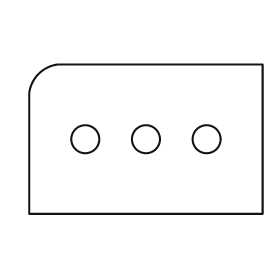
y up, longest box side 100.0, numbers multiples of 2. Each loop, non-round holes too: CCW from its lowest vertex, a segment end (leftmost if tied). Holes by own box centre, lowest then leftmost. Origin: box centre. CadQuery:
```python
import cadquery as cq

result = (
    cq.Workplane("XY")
    .moveTo(-50.0, -32.0)
    .lineTo(50.0, -32.0)
    .lineTo(50.0, 32.0)
    .lineTo(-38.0, 32.0)
    .threePointArc((-46.0, 28.0), (-50.0, 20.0))
    .close()
    .moveTo(-26.0, 0.0)
    .circle(6.0)
    .moveTo(0.0, 0.0)
    .circle(6.0)
    .moveTo(26.0, 0.0)
    .circle(6.0)
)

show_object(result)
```